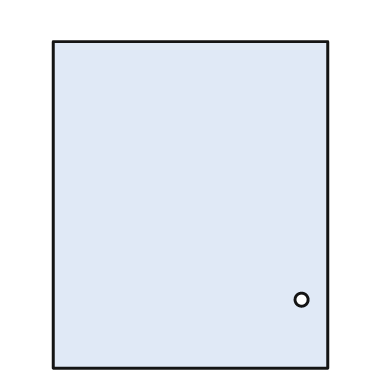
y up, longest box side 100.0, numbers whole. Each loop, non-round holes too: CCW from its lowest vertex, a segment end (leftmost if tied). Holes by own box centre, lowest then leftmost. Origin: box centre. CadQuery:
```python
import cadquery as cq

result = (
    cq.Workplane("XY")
    .moveTo(-42.0, -50.0)
    .lineTo(42.0, -50.0)
    .lineTo(42.0, 50.0)
    .lineTo(-42.0, 50.0)
    .close()
    .moveTo(34.0, -29.0)
    .circle(2.0)
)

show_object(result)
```